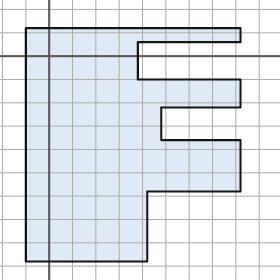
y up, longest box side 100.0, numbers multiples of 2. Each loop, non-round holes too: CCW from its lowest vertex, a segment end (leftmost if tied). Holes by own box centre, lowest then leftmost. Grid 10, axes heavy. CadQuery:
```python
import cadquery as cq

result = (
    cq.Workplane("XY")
    .moveTo(-10.0, -88.0)
    .lineTo(42.0, -88.0)
    .lineTo(42.0, -58.0)
    .lineTo(82.0, -58.0)
    .lineTo(82.0, -36.0)
    .lineTo(48.0, -36.0)
    .lineTo(48.0, -22.0)
    .lineTo(82.0, -22.0)
    .lineTo(82.0, -10.0)
    .lineTo(38.0, -10.0)
    .lineTo(38.0, 6.0)
    .lineTo(82.0, 6.0)
    .lineTo(82.0, 12.0)
    .lineTo(-10.0, 12.0)
    .close()
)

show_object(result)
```